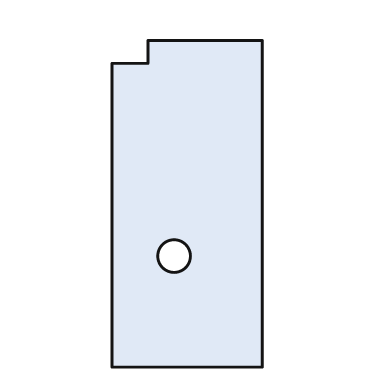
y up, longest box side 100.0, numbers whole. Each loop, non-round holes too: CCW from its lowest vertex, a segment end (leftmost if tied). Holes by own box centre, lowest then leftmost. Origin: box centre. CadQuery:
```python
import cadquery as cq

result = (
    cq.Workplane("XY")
    .moveTo(-23.0, -50.0)
    .lineTo(23.0, -50.0)
    .lineTo(23.0, 50.0)
    .lineTo(-12.0, 50.0)
    .lineTo(-12.0, 43.0)
    .lineTo(-23.0, 43.0)
    .close()
    .moveTo(-4.0, -16.0)
    .circle(5.0)
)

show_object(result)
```